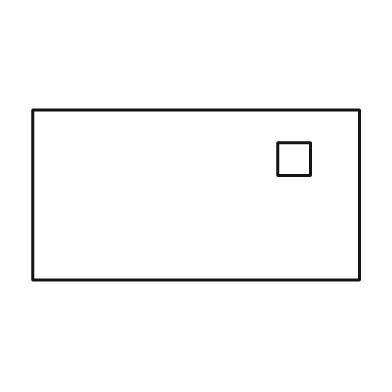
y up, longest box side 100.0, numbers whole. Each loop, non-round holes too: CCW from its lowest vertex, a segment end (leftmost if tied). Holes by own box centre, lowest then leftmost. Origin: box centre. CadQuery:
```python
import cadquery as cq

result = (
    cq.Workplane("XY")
    .moveTo(-50.0, -26.0)
    .lineTo(50.0, -26.0)
    .lineTo(50.0, 26.0)
    .lineTo(-50.0, 26.0)
    .close()
    .moveTo(25.0, 6.0)
    .lineTo(35.0, 6.0)
    .lineTo(35.0, 16.0)
    .lineTo(25.0, 16.0)
    .close()
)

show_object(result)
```